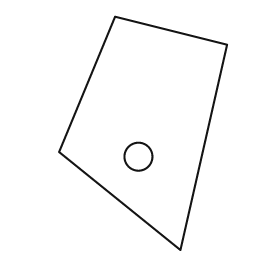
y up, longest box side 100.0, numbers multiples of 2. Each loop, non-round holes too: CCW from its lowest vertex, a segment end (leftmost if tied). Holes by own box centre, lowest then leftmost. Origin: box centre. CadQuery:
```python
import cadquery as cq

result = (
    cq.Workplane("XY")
    .moveTo(16.0, -50.0)
    .lineTo(36.0, 38.0)
    .lineTo(-12.0, 50.0)
    .lineTo(-36.0, -8.0)
    .close()
    .moveTo(-2.0, -10.0)
    .circle(6.0)
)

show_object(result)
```